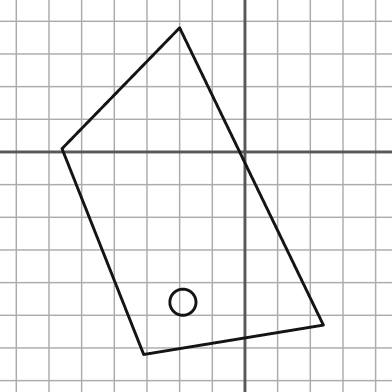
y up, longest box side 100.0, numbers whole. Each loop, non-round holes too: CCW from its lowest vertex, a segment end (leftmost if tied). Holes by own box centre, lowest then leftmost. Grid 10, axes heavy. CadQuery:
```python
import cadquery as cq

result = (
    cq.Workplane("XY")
    .moveTo(-31.0, -62.0)
    .lineTo(24.0, -53.0)
    .lineTo(-20.0, 38.0)
    .lineTo(-56.0, 1.0)
    .close()
    .moveTo(-19.0, -46.0)
    .circle(4.0)
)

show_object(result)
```